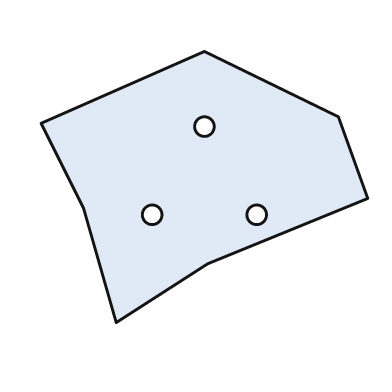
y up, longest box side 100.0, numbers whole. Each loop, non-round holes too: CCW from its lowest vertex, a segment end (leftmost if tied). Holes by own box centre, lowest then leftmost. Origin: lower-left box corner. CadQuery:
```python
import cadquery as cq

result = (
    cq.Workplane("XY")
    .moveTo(23.0, 0.0)
    .lineTo(51.0, 18.0)
    .lineTo(100.0, 38.0)
    .lineTo(91.0, 63.0)
    .lineTo(50.0, 83.0)
    .lineTo(0.0, 61.0)
    .lineTo(13.0, 35.0)
    .close()
    .moveTo(34.0, 33.0)
    .circle(3.0)
    .moveTo(66.0, 33.0)
    .circle(3.0)
    .moveTo(50.0, 60.0)
    .circle(3.0)
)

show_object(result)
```